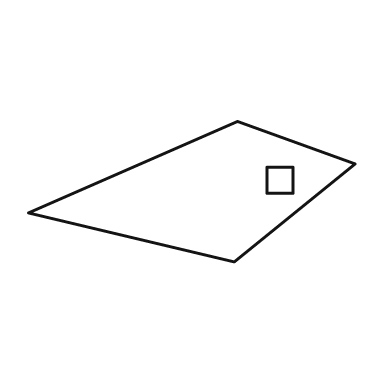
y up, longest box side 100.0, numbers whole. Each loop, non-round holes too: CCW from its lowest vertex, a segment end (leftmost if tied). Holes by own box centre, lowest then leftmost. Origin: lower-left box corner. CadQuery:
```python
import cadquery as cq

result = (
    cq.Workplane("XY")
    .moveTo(63.0, 0.0)
    .lineTo(100.0, 30.0)
    .lineTo(64.0, 43.0)
    .lineTo(0.0, 15.0)
    .close()
    .moveTo(73.0, 21.0)
    .lineTo(81.0, 21.0)
    .lineTo(81.0, 29.0)
    .lineTo(73.0, 29.0)
    .close()
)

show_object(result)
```